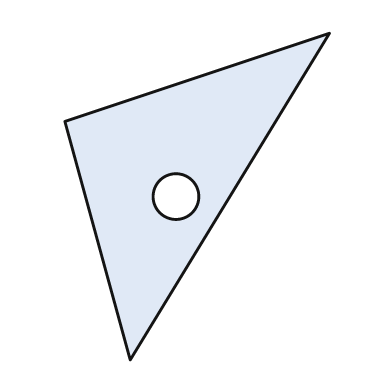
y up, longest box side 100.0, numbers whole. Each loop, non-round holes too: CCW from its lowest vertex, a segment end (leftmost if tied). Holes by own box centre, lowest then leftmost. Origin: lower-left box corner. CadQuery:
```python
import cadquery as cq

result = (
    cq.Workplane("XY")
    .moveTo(20.0, 0.0)
    .lineTo(81.0, 100.0)
    .lineTo(0.0, 73.0)
    .close()
    .moveTo(34.0, 50.0)
    .circle(7.0)
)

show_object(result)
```